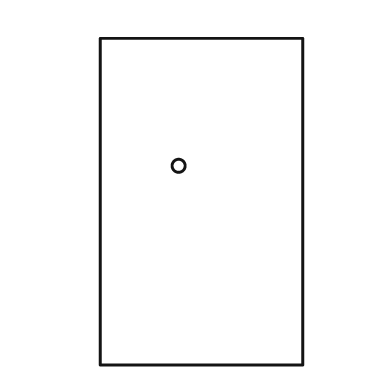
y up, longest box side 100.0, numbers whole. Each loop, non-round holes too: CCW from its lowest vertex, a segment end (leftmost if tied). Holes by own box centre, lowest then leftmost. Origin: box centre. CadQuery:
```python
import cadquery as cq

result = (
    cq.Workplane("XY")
    .moveTo(-31.0, -50.0)
    .lineTo(31.0, -50.0)
    .lineTo(31.0, 50.0)
    .lineTo(-31.0, 50.0)
    .close()
    .moveTo(-7.0, 11.0)
    .circle(2.0)
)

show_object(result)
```